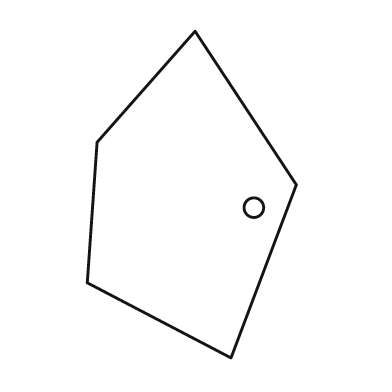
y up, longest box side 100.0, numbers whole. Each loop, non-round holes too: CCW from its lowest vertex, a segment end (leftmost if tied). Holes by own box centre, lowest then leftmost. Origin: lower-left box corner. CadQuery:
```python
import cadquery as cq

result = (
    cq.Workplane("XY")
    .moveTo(44.0, 0.0)
    .lineTo(64.0, 53.0)
    .lineTo(33.0, 100.0)
    .lineTo(3.0, 66.0)
    .lineTo(0.0, 23.0)
    .close()
    .moveTo(51.0, 46.0)
    .circle(3.0)
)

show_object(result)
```